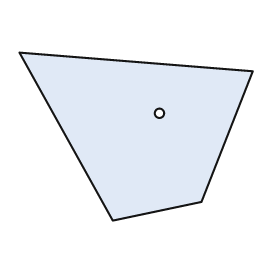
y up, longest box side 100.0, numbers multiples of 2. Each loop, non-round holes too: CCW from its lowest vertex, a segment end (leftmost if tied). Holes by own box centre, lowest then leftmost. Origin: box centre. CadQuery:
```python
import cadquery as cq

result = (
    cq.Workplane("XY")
    .moveTo(-10.0, -36.0)
    .lineTo(28.0, -28.0)
    .lineTo(50.0, 28.0)
    .lineTo(-50.0, 36.0)
    .close()
    .moveTo(10.0, 10.0)
    .circle(2.0)
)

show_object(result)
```